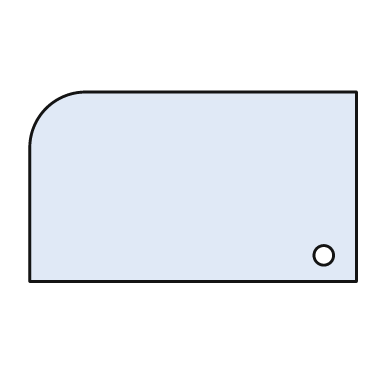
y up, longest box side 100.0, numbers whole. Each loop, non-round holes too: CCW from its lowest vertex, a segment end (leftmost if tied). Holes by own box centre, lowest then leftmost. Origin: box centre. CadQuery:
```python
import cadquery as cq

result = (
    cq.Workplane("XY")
    .moveTo(-50.0, -29.0)
    .lineTo(50.0, -29.0)
    .lineTo(50.0, 29.0)
    .lineTo(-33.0, 29.0)
    .threePointArc((-45.0, 24.0), (-50.0, 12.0))
    .close()
    .moveTo(40.0, -21.0)
    .circle(3.0)
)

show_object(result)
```